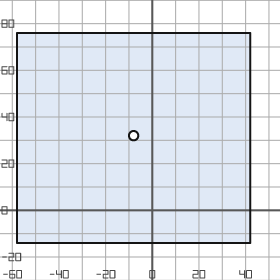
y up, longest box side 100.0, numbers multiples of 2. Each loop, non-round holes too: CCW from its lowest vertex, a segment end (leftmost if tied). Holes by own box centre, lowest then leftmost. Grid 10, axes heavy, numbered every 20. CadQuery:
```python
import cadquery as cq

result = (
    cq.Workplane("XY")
    .moveTo(-58.0, -14.0)
    .lineTo(42.0, -14.0)
    .lineTo(42.0, 76.0)
    .lineTo(-58.0, 76.0)
    .close()
    .moveTo(-8.0, 32.0)
    .circle(2.0)
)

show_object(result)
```